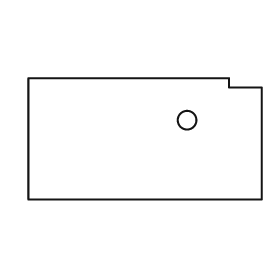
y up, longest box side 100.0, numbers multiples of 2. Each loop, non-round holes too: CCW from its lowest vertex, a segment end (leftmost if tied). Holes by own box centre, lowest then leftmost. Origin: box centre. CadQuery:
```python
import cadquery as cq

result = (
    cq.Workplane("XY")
    .moveTo(-50.0, -26.0)
    .lineTo(50.0, -26.0)
    .lineTo(50.0, 22.0)
    .lineTo(36.0, 22.0)
    .lineTo(36.0, 26.0)
    .lineTo(-50.0, 26.0)
    .close()
    .moveTo(18.0, 8.0)
    .circle(4.0)
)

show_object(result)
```